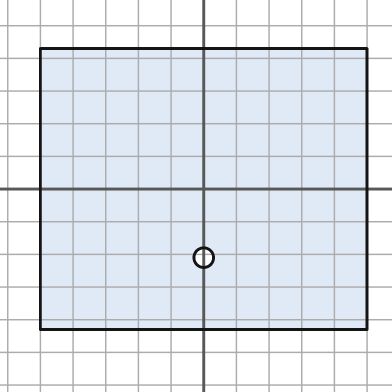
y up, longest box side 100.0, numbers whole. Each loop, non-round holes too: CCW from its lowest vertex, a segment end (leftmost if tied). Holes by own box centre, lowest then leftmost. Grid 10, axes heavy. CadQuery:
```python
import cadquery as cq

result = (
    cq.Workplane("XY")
    .moveTo(-50.0, -43.0)
    .lineTo(50.0, -43.0)
    .lineTo(50.0, 43.0)
    .lineTo(-50.0, 43.0)
    .close()
    .moveTo(0.0, -21.0)
    .circle(3.0)
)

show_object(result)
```